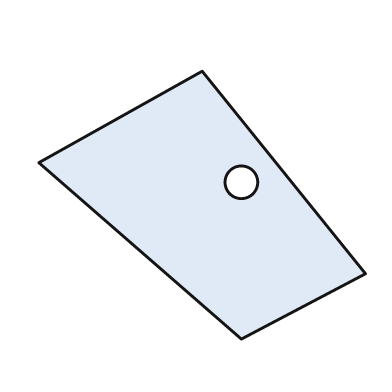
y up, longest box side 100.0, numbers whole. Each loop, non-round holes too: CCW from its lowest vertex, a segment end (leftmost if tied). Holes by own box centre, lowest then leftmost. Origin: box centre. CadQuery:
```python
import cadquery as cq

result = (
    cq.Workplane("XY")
    .moveTo(12.0, -41.0)
    .lineTo(50.0, -21.0)
    .lineTo(0.0, 41.0)
    .lineTo(-50.0, 13.0)
    .close()
    .moveTo(12.0, 7.0)
    .circle(5.0)
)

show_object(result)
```